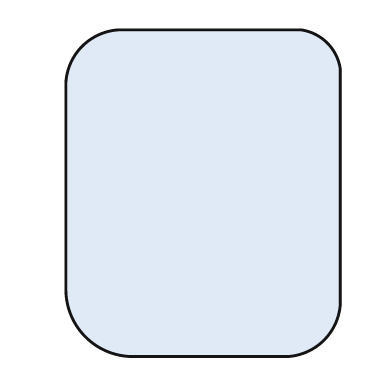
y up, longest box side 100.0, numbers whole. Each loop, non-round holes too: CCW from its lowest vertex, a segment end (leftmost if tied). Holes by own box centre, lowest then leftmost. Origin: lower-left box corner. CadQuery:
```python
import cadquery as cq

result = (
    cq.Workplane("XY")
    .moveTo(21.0, 0.0)
    .lineTo(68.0, 0.0)
    .threePointArc((79.0, 5.0), (84.0, 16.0))
    .lineTo(84.0, 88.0)
    .threePointArc((80.0, 96.0), (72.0, 100.0))
    .lineTo(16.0, 100.0)
    .threePointArc((5.0, 95.0), (0.0, 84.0))
    .lineTo(0.0, 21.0)
    .threePointArc((6.0, 6.0), (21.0, 0.0))
    .close()
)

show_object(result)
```